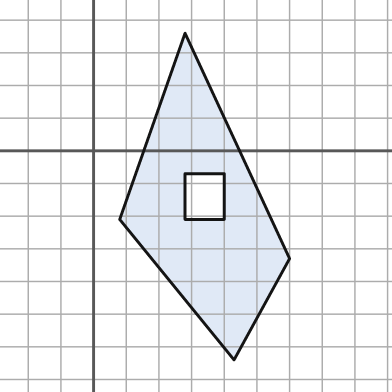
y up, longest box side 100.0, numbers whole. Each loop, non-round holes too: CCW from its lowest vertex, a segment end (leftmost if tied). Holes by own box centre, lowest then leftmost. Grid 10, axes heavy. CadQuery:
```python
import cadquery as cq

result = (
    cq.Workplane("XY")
    .moveTo(43.0, -64.0)
    .lineTo(60.0, -33.0)
    .lineTo(28.0, 36.0)
    .lineTo(8.0, -21.0)
    .close()
    .moveTo(28.0, -21.0)
    .lineTo(40.0, -21.0)
    .lineTo(40.0, -7.0)
    .lineTo(28.0, -7.0)
    .close()
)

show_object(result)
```